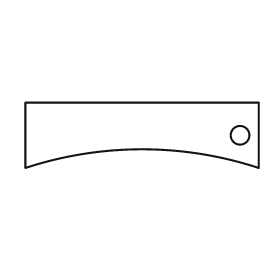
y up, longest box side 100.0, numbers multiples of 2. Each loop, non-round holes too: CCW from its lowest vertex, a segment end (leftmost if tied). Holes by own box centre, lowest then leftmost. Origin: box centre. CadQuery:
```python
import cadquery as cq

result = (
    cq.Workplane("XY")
    .moveTo(-50.0, -14.0)
    .threePointArc((0.0, -6.0), (50.0, -14.0))
    .lineTo(50.0, 14.0)
    .lineTo(-50.0, 14.0)
    .close()
    .moveTo(42.0, 0.0)
    .circle(4.0)
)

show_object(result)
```